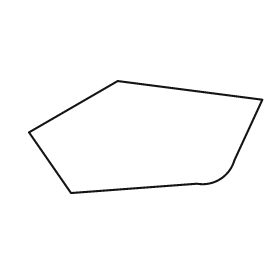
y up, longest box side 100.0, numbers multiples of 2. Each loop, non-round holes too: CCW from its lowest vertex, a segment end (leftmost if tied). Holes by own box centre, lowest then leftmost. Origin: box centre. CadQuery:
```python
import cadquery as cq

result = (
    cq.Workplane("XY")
    .moveTo(-32.0, -24.0)
    .lineTo(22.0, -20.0)
    .threePointArc((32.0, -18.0), (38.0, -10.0))
    .lineTo(50.0, 16.0)
    .lineTo(-12.0, 24.0)
    .lineTo(-50.0, 2.0)
    .close()
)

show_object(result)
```